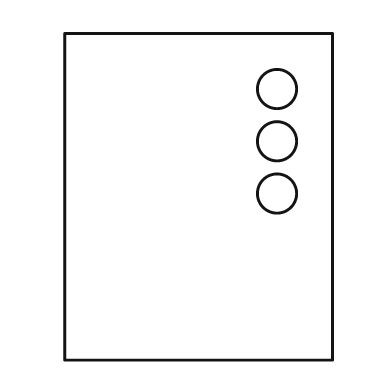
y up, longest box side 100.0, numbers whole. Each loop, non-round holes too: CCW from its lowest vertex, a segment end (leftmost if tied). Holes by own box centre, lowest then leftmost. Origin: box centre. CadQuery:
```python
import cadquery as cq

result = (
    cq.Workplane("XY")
    .moveTo(-41.0, -50.0)
    .lineTo(41.0, -50.0)
    .lineTo(41.0, 50.0)
    .lineTo(-41.0, 50.0)
    .close()
    .moveTo(24.0, 1.0)
    .circle(6.0)
    .moveTo(24.0, 17.0)
    .circle(6.0)
    .moveTo(24.0, 33.0)
    .circle(6.0)
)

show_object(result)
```